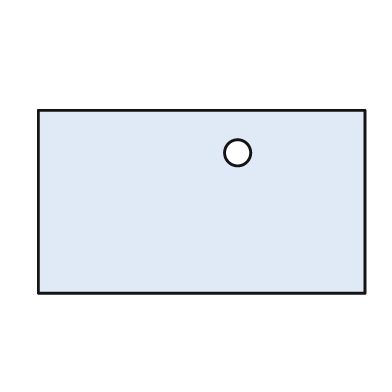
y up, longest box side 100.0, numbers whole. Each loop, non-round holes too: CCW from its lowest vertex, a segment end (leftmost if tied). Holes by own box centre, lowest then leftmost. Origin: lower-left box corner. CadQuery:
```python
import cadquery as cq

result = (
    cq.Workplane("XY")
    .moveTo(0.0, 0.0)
    .lineTo(100.0, 0.0)
    .lineTo(100.0, 56.0)
    .lineTo(0.0, 56.0)
    .close()
    .moveTo(61.0, 43.0)
    .circle(4.0)
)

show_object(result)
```